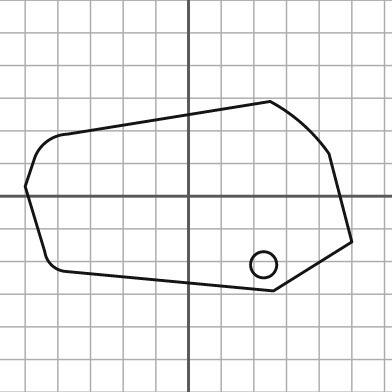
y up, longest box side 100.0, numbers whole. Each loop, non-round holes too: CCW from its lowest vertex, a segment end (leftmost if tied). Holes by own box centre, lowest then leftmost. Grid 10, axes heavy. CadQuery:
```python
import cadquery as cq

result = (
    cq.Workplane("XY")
    .moveTo(26.0, -29.0)
    .lineTo(50.0, -14.0)
    .lineTo(43.0, 13.0)
    .threePointArc((35.0, 22.0), (25.0, 29.0))
    .lineTo(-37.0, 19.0)
    .threePointArc((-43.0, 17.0), (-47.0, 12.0))
    .lineTo(-50.0, 3.0)
    .lineTo(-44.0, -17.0)
    .threePointArc((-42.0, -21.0), (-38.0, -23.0))
    .close()
    .moveTo(23.0, -21.0)
    .circle(4.0)
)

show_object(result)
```